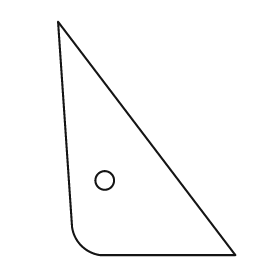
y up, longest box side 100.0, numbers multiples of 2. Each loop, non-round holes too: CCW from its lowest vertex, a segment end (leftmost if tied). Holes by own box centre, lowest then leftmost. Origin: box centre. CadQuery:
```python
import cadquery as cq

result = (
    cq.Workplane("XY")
    .moveTo(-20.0, -50.0)
    .lineTo(38.0, -50.0)
    .lineTo(-38.0, 50.0)
    .lineTo(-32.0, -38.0)
    .threePointArc((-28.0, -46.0), (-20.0, -50.0))
    .close()
    .moveTo(-18.0, -18.0)
    .circle(4.0)
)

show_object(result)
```